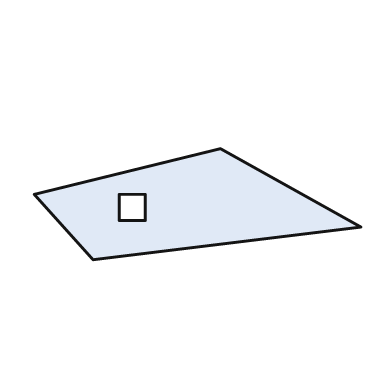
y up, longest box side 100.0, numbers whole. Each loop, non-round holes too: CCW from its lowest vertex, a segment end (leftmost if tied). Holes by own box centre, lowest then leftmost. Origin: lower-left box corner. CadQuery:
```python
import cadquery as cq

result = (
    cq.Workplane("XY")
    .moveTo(18.0, 0.0)
    .lineTo(100.0, 10.0)
    .lineTo(57.0, 34.0)
    .lineTo(0.0, 20.0)
    .close()
    .moveTo(26.0, 12.0)
    .lineTo(34.0, 12.0)
    .lineTo(34.0, 20.0)
    .lineTo(26.0, 20.0)
    .close()
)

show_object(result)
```